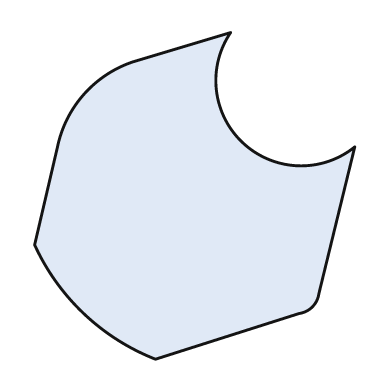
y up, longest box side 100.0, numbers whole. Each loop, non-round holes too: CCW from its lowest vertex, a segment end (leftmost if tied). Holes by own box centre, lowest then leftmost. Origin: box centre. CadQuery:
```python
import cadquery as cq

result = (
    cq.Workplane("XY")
    .moveTo(-12.0, -50.0)
    .lineTo(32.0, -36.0)
    .threePointArc((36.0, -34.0), (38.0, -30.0))
    .lineTo(49.0, 15.0)
    .threePointArc((15.0, 16.0), (11.0, 50.0))
    .lineTo(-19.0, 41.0)
    .threePointArc((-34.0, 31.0), (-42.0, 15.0))
    .lineTo(-49.0, -15.0)
    .threePointArc((-34.0, -36.0), (-12.0, -50.0))
    .close()
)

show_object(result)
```